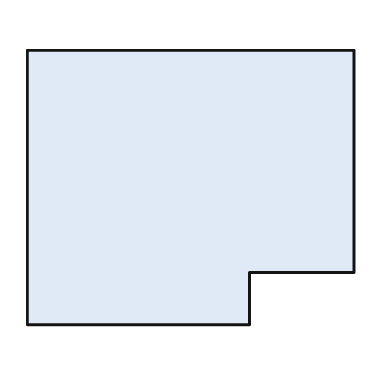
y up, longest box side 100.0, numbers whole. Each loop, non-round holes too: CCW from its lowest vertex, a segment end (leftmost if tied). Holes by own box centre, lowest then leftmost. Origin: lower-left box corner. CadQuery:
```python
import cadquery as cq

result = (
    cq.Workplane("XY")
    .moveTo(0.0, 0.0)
    .lineTo(68.0, 0.0)
    .lineTo(68.0, 16.0)
    .lineTo(100.0, 16.0)
    .lineTo(100.0, 84.0)
    .lineTo(0.0, 84.0)
    .close()
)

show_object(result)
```